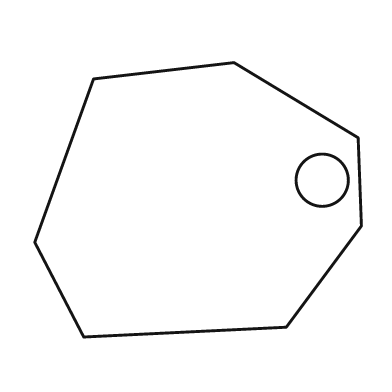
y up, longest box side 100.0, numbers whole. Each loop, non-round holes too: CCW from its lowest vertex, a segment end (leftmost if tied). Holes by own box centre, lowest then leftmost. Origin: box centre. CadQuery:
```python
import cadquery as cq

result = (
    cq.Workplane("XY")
    .moveTo(-35.0, -42.0)
    .lineTo(27.0, -39.0)
    .lineTo(50.0, -8.0)
    .lineTo(49.0, 19.0)
    .lineTo(11.0, 42.0)
    .lineTo(-32.0, 37.0)
    .lineTo(-50.0, -13.0)
    .close()
    .moveTo(38.0, 6.0)
    .circle(8.0)
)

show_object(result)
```